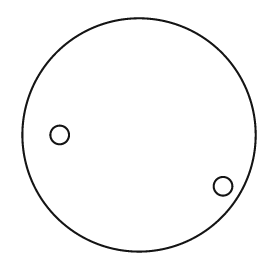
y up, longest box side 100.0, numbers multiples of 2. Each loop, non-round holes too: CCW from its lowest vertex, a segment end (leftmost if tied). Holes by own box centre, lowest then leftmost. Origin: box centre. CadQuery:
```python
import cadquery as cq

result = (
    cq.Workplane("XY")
    .moveTo(0.0, 0.0)
    .circle(50.0)
    .moveTo(36.0, -22.0)
    .circle(4.0)
    .moveTo(-34.0, 0.0)
    .circle(4.0)
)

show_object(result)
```